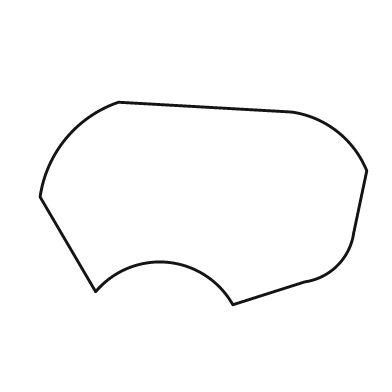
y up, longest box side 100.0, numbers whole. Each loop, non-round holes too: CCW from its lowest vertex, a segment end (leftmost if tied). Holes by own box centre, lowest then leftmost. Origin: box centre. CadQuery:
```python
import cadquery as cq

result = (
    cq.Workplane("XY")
    .moveTo(9.0, -31.0)
    .lineTo(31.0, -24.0)
    .threePointArc((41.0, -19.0), (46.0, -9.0))
    .lineTo(50.0, 10.0)
    .threePointArc((41.0, 22.0), (27.0, 28.0))
    .lineTo(-26.0, 31.0)
    .threePointArc((-42.0, 20.0), (-50.0, 2.0))
    .lineTo(-33.0, -27.0)
    .threePointArc((-11.0, -18.0), (9.0, -31.0))
    .close()
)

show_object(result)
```